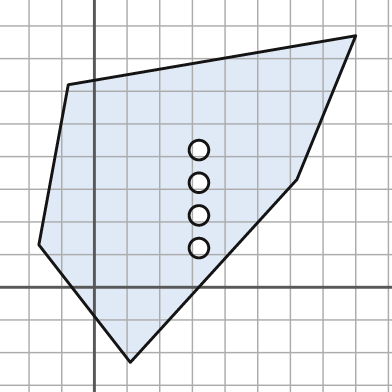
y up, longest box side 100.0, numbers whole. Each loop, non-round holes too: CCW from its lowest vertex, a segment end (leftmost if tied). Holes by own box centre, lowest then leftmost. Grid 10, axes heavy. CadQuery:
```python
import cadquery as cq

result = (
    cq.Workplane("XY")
    .moveTo(11.0, -23.0)
    .lineTo(62.0, 33.0)
    .lineTo(80.0, 77.0)
    .lineTo(-8.0, 62.0)
    .lineTo(-17.0, 13.0)
    .close()
    .moveTo(32.0, 12.0)
    .circle(3.0)
    .moveTo(32.0, 22.0)
    .circle(3.0)
    .moveTo(32.0, 32.0)
    .circle(3.0)
    .moveTo(32.0, 42.0)
    .circle(3.0)
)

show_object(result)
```